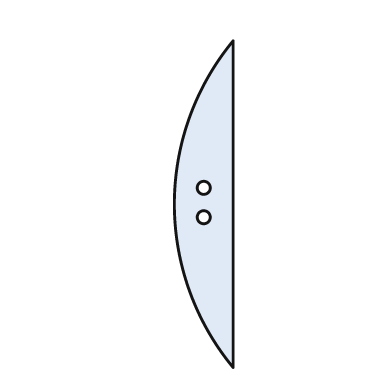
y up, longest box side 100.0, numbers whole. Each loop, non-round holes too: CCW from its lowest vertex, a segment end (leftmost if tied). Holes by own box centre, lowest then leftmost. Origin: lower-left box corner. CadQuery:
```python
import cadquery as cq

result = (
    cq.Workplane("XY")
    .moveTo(18.0, 0.0)
    .lineTo(18.0, 100.0)
    .threePointArc((0.0, 50.0), (18.0, 0.0))
    .close()
    .moveTo(9.0, 46.0)
    .circle(2.0)
    .moveTo(9.0, 55.0)
    .circle(2.0)
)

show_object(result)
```